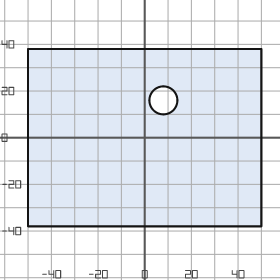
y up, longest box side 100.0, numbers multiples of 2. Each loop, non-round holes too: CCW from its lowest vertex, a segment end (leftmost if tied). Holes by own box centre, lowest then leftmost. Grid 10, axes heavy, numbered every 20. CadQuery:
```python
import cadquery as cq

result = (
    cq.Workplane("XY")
    .moveTo(-50.0, -38.0)
    .lineTo(50.0, -38.0)
    .lineTo(50.0, 38.0)
    .lineTo(-50.0, 38.0)
    .close()
    .moveTo(8.0, 16.0)
    .circle(6.0)
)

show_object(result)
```